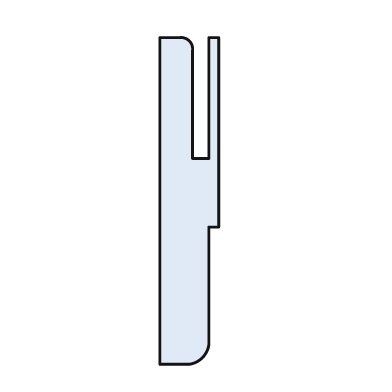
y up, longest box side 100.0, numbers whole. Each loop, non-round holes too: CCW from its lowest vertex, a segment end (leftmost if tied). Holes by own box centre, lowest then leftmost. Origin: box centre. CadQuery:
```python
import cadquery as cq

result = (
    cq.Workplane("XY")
    .moveTo(-9.0, -50.0)
    .lineTo(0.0, -50.0)
    .threePointArc((4.0, -48.0), (6.0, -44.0))
    .lineTo(6.0, -8.0)
    .lineTo(9.0, -8.0)
    .lineTo(9.0, 50.0)
    .lineTo(6.0, 50.0)
    .lineTo(6.0, 13.0)
    .lineTo(1.0, 13.0)
    .lineTo(1.0, 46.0)
    .threePointArc((0.0, 49.0), (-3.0, 50.0))
    .lineTo(-9.0, 50.0)
    .close()
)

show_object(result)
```